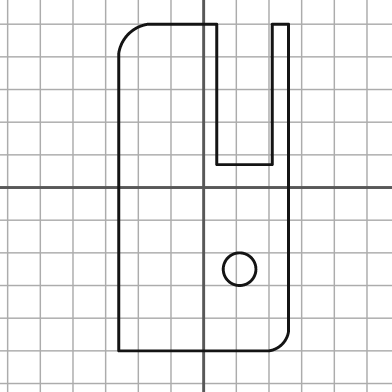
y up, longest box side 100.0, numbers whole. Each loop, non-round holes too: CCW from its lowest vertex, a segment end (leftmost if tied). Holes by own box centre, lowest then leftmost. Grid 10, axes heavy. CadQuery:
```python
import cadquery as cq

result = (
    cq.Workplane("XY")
    .moveTo(-26.0, -50.0)
    .lineTo(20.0, -50.0)
    .threePointArc((24.0, -48.0), (26.0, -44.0))
    .lineTo(26.0, 50.0)
    .lineTo(21.0, 50.0)
    .lineTo(21.0, 7.0)
    .lineTo(4.0, 7.0)
    .lineTo(4.0, 50.0)
    .lineTo(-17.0, 50.0)
    .threePointArc((-23.0, 47.0), (-26.0, 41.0))
    .close()
    .moveTo(11.0, -25.0)
    .circle(5.0)
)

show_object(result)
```